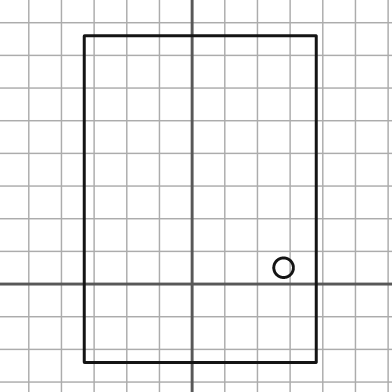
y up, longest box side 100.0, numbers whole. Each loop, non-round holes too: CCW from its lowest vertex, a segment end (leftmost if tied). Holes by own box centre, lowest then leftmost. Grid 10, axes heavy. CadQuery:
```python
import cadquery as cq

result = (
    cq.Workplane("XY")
    .moveTo(-33.0, -24.0)
    .lineTo(38.0, -24.0)
    .lineTo(38.0, 76.0)
    .lineTo(-33.0, 76.0)
    .close()
    .moveTo(28.0, 5.0)
    .circle(3.0)
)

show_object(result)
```